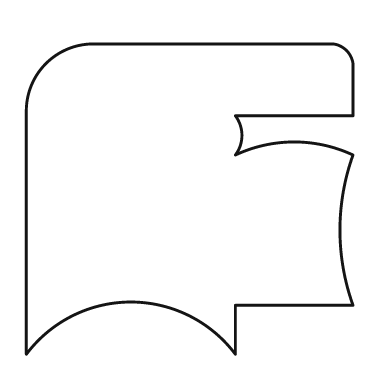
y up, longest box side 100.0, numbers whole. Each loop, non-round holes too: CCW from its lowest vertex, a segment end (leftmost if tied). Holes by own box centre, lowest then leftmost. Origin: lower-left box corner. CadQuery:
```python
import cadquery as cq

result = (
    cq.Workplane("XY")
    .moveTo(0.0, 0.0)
    .threePointArc((32.0, 16.0), (64.0, 0.0))
    .lineTo(64.0, 15.0)
    .lineTo(100.0, 15.0)
    .threePointArc((96.0, 38.0), (100.0, 61.0))
    .threePointArc((82.0, 65.0), (64.0, 61.0))
    .threePointArc((66.0, 67.0), (64.0, 73.0))
    .lineTo(100.0, 73.0)
    .lineTo(100.0, 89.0)
    .threePointArc((98.0, 93.0), (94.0, 95.0))
    .lineTo(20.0, 95.0)
    .threePointArc((6.0, 89.0), (0.0, 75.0))
    .close()
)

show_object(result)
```